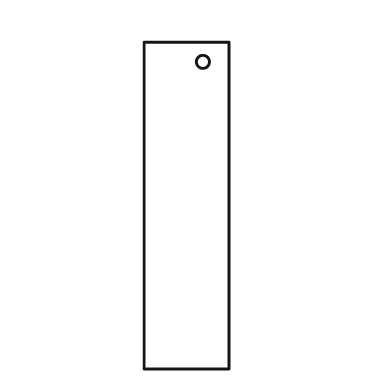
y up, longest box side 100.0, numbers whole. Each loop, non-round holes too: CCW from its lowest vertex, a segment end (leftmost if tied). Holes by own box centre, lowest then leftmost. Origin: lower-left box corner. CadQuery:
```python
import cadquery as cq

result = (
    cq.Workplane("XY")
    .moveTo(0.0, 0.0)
    .lineTo(26.0, 0.0)
    .lineTo(26.0, 100.0)
    .lineTo(0.0, 100.0)
    .close()
    .moveTo(18.0, 94.0)
    .circle(2.0)
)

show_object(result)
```